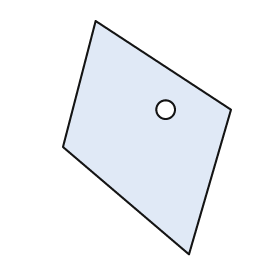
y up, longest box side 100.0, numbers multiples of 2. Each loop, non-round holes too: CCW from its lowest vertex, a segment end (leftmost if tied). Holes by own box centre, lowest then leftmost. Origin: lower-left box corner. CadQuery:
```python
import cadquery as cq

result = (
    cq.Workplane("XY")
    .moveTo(54.0, 0.0)
    .lineTo(72.0, 62.0)
    .lineTo(14.0, 100.0)
    .lineTo(0.0, 46.0)
    .close()
    .moveTo(44.0, 62.0)
    .circle(4.0)
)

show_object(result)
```